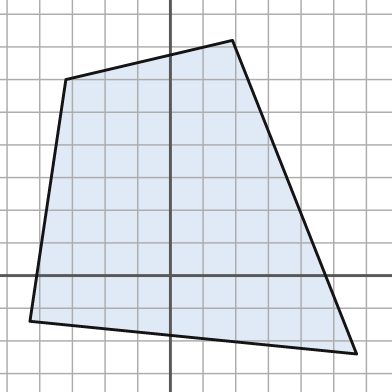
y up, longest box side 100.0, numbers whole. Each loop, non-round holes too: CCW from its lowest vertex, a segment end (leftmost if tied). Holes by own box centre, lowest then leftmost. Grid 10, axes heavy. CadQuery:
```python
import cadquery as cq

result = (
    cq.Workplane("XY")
    .moveTo(57.0, -24.0)
    .lineTo(19.0, 72.0)
    .lineTo(-32.0, 60.0)
    .lineTo(-43.0, -14.0)
    .close()
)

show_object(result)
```